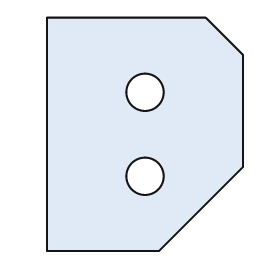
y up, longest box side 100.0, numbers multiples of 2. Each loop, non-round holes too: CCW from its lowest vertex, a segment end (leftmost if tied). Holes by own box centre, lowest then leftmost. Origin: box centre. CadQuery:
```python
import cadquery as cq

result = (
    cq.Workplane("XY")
    .moveTo(-42.0, -50.0)
    .lineTo(6.0, -50.0)
    .lineTo(42.0, -14.0)
    .lineTo(42.0, 34.0)
    .lineTo(26.0, 50.0)
    .lineTo(-42.0, 50.0)
    .close()
    .moveTo(0.0, -18.0)
    .circle(8.0)
    .moveTo(0.0, 18.0)
    .circle(8.0)
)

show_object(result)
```